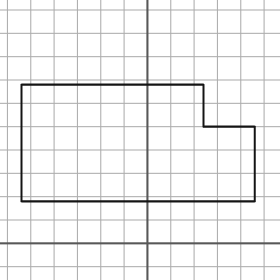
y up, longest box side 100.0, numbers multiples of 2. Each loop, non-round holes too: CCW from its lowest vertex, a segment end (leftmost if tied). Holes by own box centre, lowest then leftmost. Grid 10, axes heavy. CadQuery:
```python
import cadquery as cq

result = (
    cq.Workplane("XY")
    .moveTo(-54.0, 18.0)
    .lineTo(46.0, 18.0)
    .lineTo(46.0, 50.0)
    .lineTo(24.0, 50.0)
    .lineTo(24.0, 68.0)
    .lineTo(-54.0, 68.0)
    .close()
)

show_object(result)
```